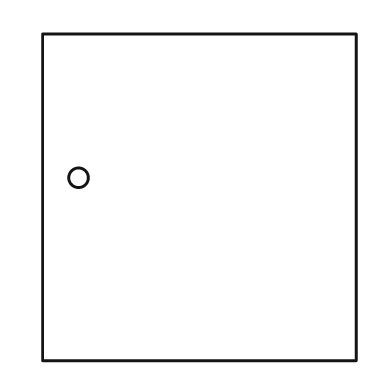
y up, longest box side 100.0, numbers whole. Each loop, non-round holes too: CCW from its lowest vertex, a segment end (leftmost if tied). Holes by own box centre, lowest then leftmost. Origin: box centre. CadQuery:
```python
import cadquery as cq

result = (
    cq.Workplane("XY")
    .moveTo(-48.0, -50.0)
    .lineTo(48.0, -50.0)
    .lineTo(48.0, 50.0)
    .lineTo(-48.0, 50.0)
    .close()
    .moveTo(-37.0, 6.0)
    .circle(3.0)
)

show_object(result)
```